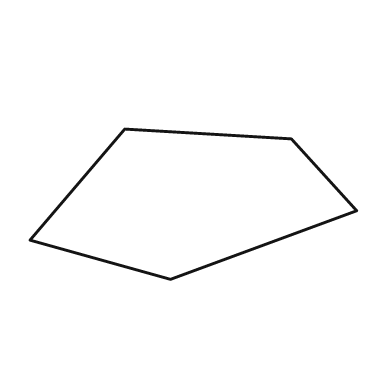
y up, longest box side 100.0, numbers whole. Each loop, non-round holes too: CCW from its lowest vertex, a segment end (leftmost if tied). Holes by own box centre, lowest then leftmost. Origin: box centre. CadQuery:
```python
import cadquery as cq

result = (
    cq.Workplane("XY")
    .moveTo(-7.0, -23.0)
    .lineTo(50.0, -2.0)
    .lineTo(30.0, 20.0)
    .lineTo(-21.0, 23.0)
    .lineTo(-50.0, -11.0)
    .close()
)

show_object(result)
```